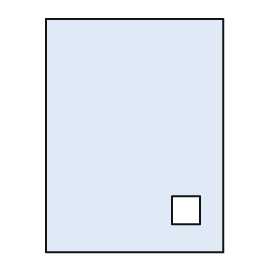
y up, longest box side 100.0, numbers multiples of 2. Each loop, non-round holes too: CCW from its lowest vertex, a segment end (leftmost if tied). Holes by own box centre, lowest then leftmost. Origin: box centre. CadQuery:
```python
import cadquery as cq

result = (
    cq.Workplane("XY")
    .moveTo(-38.0, -50.0)
    .lineTo(38.0, -50.0)
    .lineTo(38.0, 50.0)
    .lineTo(-38.0, 50.0)
    .close()
    .moveTo(16.0, -38.0)
    .lineTo(28.0, -38.0)
    .lineTo(28.0, -26.0)
    .lineTo(16.0, -26.0)
    .close()
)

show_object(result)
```